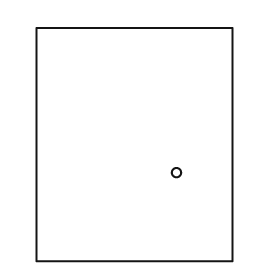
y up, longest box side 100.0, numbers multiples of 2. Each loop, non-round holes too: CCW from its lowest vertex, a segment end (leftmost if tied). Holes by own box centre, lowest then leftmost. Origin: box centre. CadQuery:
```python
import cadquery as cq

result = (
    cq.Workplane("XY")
    .moveTo(-42.0, -50.0)
    .lineTo(42.0, -50.0)
    .lineTo(42.0, 50.0)
    .lineTo(-42.0, 50.0)
    .close()
    .moveTo(18.0, -12.0)
    .circle(2.0)
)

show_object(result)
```